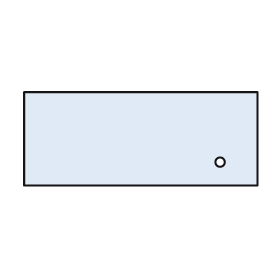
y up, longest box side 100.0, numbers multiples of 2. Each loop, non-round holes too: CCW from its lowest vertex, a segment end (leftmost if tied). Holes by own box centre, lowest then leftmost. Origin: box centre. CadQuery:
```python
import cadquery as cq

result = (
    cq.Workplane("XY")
    .moveTo(-50.0, -20.0)
    .lineTo(50.0, -20.0)
    .lineTo(50.0, 20.0)
    .lineTo(-50.0, 20.0)
    .close()
    .moveTo(34.0, -10.0)
    .circle(2.0)
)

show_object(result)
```